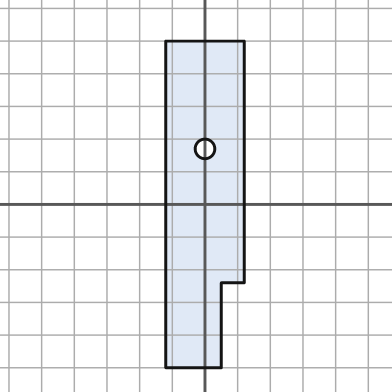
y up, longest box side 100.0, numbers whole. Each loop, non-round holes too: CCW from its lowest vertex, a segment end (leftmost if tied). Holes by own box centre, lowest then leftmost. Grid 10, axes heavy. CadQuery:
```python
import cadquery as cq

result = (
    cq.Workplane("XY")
    .moveTo(-12.0, -50.0)
    .lineTo(5.0, -50.0)
    .lineTo(5.0, -24.0)
    .lineTo(12.0, -24.0)
    .lineTo(12.0, 50.0)
    .lineTo(-12.0, 50.0)
    .close()
    .moveTo(0.0, 17.0)
    .circle(3.0)
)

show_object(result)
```